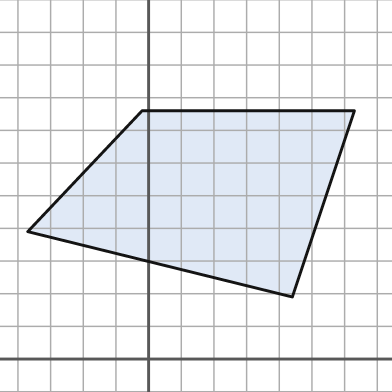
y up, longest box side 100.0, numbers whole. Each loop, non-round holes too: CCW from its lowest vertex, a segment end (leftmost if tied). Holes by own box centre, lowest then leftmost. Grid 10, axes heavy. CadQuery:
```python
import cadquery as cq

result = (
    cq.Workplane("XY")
    .moveTo(44.0, 19.0)
    .lineTo(63.0, 76.0)
    .lineTo(-2.0, 76.0)
    .lineTo(-37.0, 39.0)
    .close()
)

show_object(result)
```